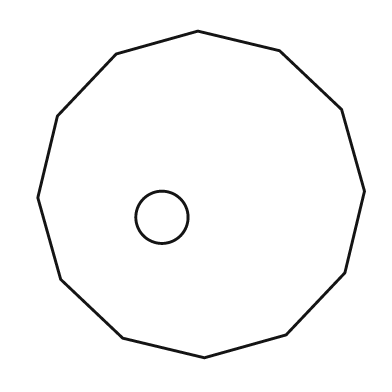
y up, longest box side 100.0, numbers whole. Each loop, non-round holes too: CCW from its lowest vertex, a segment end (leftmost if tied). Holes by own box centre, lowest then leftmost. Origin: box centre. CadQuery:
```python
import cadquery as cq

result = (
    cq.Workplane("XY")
    .moveTo(1.0, -50.0)
    .lineTo(26.0, -43.0)
    .lineTo(44.0, -24.0)
    .lineTo(50.0, 1.0)
    .lineTo(43.0, 26.0)
    .lineTo(24.0, 44.0)
    .lineTo(-1.0, 50.0)
    .lineTo(-26.0, 43.0)
    .lineTo(-44.0, 24.0)
    .lineTo(-50.0, -1.0)
    .lineTo(-43.0, -26.0)
    .lineTo(-24.0, -44.0)
    .close()
    .moveTo(-12.0, -7.0)
    .circle(8.0)
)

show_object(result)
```